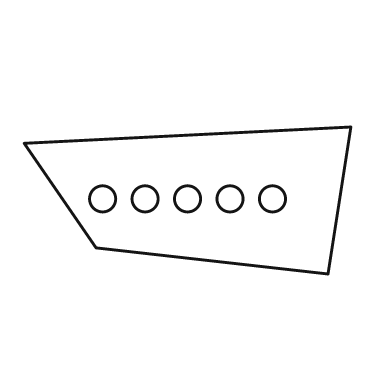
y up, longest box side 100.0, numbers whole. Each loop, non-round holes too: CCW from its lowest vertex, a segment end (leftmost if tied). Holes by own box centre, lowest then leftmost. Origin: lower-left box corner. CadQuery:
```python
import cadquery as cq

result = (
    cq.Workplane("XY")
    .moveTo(93.0, 0.0)
    .lineTo(100.0, 45.0)
    .lineTo(0.0, 40.0)
    .lineTo(22.0, 8.0)
    .close()
    .moveTo(24.0, 23.0)
    .circle(4.0)
    .moveTo(37.0, 23.0)
    .circle(4.0)
    .moveTo(50.0, 23.0)
    .circle(4.0)
    .moveTo(63.0, 23.0)
    .circle(4.0)
    .moveTo(76.0, 23.0)
    .circle(4.0)
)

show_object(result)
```